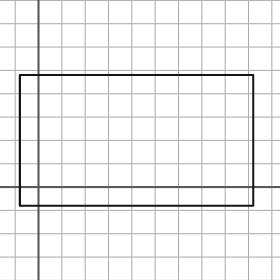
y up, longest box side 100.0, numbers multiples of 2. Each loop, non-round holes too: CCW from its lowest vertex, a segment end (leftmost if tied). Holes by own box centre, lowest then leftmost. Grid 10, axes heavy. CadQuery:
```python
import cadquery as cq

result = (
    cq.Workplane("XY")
    .moveTo(-8.0, -8.0)
    .lineTo(92.0, -8.0)
    .lineTo(92.0, 48.0)
    .lineTo(-8.0, 48.0)
    .close()
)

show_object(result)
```